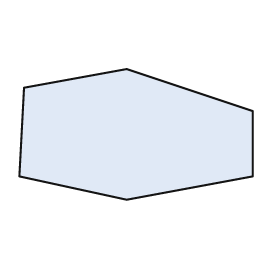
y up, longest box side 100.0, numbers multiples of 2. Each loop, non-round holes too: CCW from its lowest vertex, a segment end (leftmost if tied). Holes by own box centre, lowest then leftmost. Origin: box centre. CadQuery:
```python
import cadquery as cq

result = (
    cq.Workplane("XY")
    .moveTo(-4.0, -28.0)
    .lineTo(50.0, -18.0)
    .lineTo(50.0, 10.0)
    .lineTo(-4.0, 28.0)
    .lineTo(-48.0, 20.0)
    .lineTo(-50.0, -18.0)
    .close()
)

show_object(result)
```